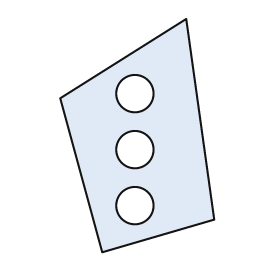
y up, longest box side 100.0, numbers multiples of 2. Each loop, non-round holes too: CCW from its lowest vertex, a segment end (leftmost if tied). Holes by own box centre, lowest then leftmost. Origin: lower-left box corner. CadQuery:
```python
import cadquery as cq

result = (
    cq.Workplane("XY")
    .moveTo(18.0, 0.0)
    .lineTo(66.0, 14.0)
    .lineTo(54.0, 100.0)
    .lineTo(0.0, 66.0)
    .close()
    .moveTo(32.0, 20.0)
    .circle(8.0)
    .moveTo(32.0, 44.0)
    .circle(8.0)
    .moveTo(32.0, 68.0)
    .circle(8.0)
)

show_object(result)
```